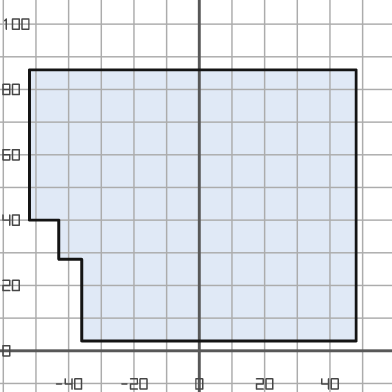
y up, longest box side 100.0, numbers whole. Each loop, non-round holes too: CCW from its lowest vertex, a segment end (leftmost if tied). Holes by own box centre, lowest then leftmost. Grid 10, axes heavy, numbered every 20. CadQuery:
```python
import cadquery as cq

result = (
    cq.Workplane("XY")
    .moveTo(-36.0, 3.0)
    .lineTo(48.0, 3.0)
    .lineTo(48.0, 86.0)
    .lineTo(-52.0, 86.0)
    .lineTo(-52.0, 40.0)
    .lineTo(-43.0, 40.0)
    .lineTo(-43.0, 28.0)
    .lineTo(-36.0, 28.0)
    .close()
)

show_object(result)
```